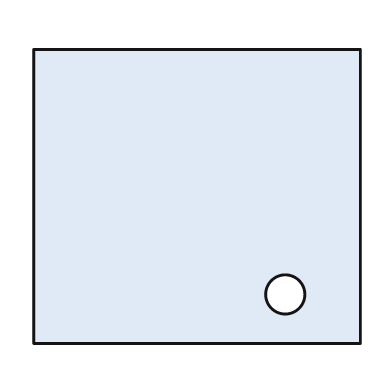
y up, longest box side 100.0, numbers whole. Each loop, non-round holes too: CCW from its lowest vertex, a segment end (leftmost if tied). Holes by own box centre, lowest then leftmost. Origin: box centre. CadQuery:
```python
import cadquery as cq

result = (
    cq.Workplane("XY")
    .moveTo(-50.0, -45.0)
    .lineTo(50.0, -45.0)
    .lineTo(50.0, 45.0)
    .lineTo(-50.0, 45.0)
    .close()
    .moveTo(27.0, -30.0)
    .circle(6.0)
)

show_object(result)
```